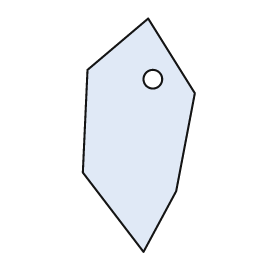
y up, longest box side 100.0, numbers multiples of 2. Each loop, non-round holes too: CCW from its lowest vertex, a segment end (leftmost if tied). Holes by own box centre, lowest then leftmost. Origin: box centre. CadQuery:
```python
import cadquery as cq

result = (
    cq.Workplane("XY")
    .moveTo(2.0, -50.0)
    .lineTo(16.0, -24.0)
    .lineTo(24.0, 18.0)
    .lineTo(4.0, 50.0)
    .lineTo(-22.0, 28.0)
    .lineTo(-24.0, -16.0)
    .close()
    .moveTo(6.0, 24.0)
    .circle(4.0)
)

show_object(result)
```